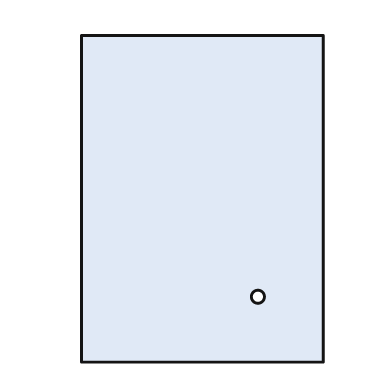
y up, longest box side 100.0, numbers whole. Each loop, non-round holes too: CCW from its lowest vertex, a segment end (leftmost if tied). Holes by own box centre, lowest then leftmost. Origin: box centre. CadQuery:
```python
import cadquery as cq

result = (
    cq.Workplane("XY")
    .moveTo(-37.0, -50.0)
    .lineTo(37.0, -50.0)
    .lineTo(37.0, 50.0)
    .lineTo(-37.0, 50.0)
    .close()
    .moveTo(17.0, -30.0)
    .circle(2.0)
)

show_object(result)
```